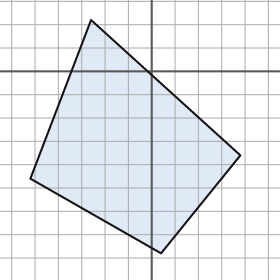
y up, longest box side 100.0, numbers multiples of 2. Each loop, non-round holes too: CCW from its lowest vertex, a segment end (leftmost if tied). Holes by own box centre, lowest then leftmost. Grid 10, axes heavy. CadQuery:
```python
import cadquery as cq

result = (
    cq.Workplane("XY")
    .moveTo(4.0, -78.0)
    .lineTo(38.0, -36.0)
    .lineTo(-26.0, 22.0)
    .lineTo(-52.0, -46.0)
    .close()
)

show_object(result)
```